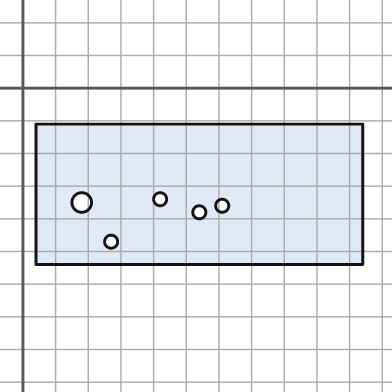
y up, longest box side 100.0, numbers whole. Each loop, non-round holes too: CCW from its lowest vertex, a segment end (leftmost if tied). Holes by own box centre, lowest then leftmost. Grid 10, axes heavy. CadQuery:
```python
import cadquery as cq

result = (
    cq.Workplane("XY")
    .moveTo(4.0, -54.0)
    .lineTo(104.0, -54.0)
    .lineTo(104.0, -11.0)
    .lineTo(4.0, -11.0)
    .close()
    .moveTo(27.0, -47.0)
    .circle(2.0)
    .moveTo(54.0, -38.0)
    .circle(2.0)
    .moveTo(61.0, -36.0)
    .circle(2.0)
    .moveTo(18.0, -35.0)
    .circle(3.0)
    .moveTo(42.0, -34.0)
    .circle(2.0)
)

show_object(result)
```